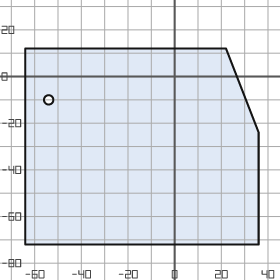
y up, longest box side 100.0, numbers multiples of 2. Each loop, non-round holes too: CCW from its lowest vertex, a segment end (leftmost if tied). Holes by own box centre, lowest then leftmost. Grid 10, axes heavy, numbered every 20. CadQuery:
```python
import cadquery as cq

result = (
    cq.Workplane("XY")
    .moveTo(-64.0, -72.0)
    .lineTo(36.0, -72.0)
    .lineTo(36.0, -24.0)
    .lineTo(22.0, 12.0)
    .lineTo(-64.0, 12.0)
    .close()
    .moveTo(-54.0, -10.0)
    .circle(2.0)
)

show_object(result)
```